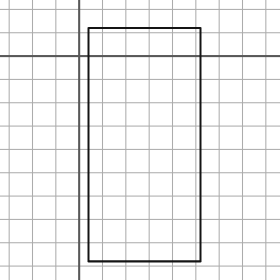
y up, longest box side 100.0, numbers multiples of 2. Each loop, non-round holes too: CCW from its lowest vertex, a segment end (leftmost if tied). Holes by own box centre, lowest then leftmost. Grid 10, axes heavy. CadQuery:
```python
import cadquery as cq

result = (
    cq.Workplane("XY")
    .moveTo(4.0, -88.0)
    .lineTo(52.0, -88.0)
    .lineTo(52.0, 12.0)
    .lineTo(4.0, 12.0)
    .close()
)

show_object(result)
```